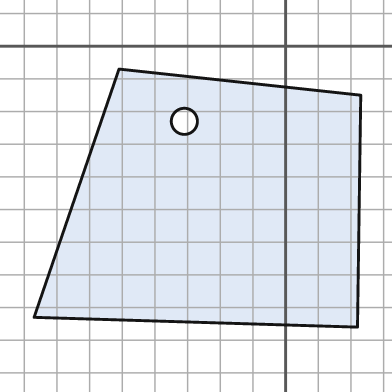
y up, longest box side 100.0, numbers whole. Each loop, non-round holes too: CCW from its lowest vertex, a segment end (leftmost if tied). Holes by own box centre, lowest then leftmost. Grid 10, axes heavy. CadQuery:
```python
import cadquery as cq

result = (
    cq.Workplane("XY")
    .moveTo(22.0, -86.0)
    .lineTo(23.0, -15.0)
    .lineTo(-51.0, -7.0)
    .lineTo(-77.0, -83.0)
    .close()
    .moveTo(-31.0, -23.0)
    .circle(4.0)
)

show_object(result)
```